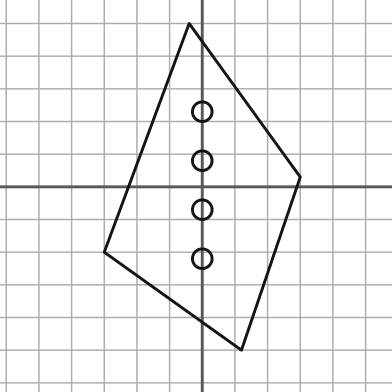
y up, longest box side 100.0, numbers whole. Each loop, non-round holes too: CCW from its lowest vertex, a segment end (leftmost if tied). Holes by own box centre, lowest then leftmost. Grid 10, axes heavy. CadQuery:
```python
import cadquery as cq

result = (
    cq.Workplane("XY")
    .moveTo(12.0, -50.0)
    .lineTo(30.0, 3.0)
    .lineTo(-4.0, 50.0)
    .lineTo(-30.0, -20.0)
    .close()
    .moveTo(0.0, -22.0)
    .circle(3.0)
    .moveTo(0.0, -7.0)
    .circle(3.0)
    .moveTo(0.0, 8.0)
    .circle(3.0)
    .moveTo(0.0, 23.0)
    .circle(3.0)
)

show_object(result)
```